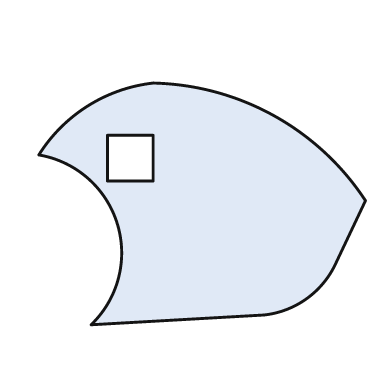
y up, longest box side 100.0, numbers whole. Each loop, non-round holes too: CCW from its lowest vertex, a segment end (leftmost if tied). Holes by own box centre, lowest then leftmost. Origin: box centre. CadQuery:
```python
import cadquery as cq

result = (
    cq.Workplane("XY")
    .moveTo(-34.0, -37.0)
    .lineTo(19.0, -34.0)
    .threePointArc((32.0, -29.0), (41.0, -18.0))
    .lineTo(50.0, 1.0)
    .threePointArc((22.0, 27.0), (-15.0, 37.0))
    .threePointArc((-35.0, 30.0), (-50.0, 15.0))
    .threePointArc((-26.0, -6.0), (-34.0, -37.0))
    .close()
    .moveTo(-29.0, 7.0)
    .lineTo(-15.0, 7.0)
    .lineTo(-15.0, 21.0)
    .lineTo(-29.0, 21.0)
    .close()
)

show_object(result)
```